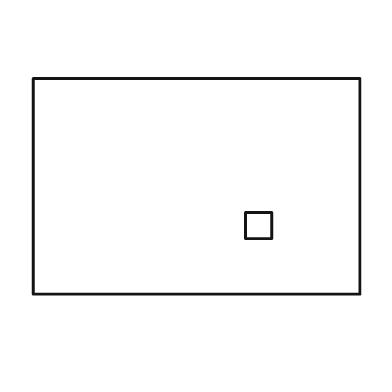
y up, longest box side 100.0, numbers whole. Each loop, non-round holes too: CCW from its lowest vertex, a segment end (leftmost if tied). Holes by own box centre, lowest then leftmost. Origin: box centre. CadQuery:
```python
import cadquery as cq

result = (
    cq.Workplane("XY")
    .moveTo(-50.0, -33.0)
    .lineTo(50.0, -33.0)
    .lineTo(50.0, 33.0)
    .lineTo(-50.0, 33.0)
    .close()
    .moveTo(15.0, -16.0)
    .lineTo(23.0, -16.0)
    .lineTo(23.0, -8.0)
    .lineTo(15.0, -8.0)
    .close()
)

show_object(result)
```